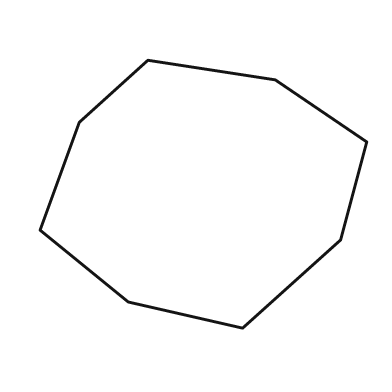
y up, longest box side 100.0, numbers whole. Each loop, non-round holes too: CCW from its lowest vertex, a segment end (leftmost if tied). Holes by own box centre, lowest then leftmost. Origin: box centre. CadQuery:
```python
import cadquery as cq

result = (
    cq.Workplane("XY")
    .moveTo(12.0, -41.0)
    .lineTo(42.0, -14.0)
    .lineTo(50.0, 16.0)
    .lineTo(22.0, 35.0)
    .lineTo(-17.0, 41.0)
    .lineTo(-38.0, 22.0)
    .lineTo(-50.0, -11.0)
    .lineTo(-23.0, -33.0)
    .close()
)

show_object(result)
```